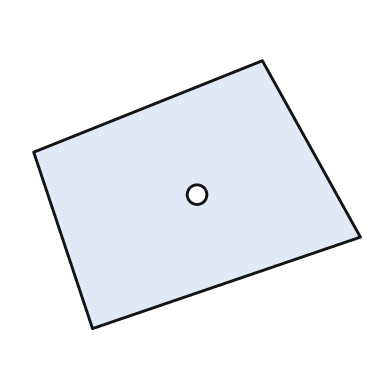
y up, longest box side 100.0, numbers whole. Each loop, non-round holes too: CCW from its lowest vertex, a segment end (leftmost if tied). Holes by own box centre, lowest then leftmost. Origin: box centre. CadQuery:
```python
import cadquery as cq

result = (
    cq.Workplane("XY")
    .moveTo(-32.0, -41.0)
    .lineTo(50.0, -13.0)
    .lineTo(20.0, 41.0)
    .lineTo(-50.0, 13.0)
    .close()
    .moveTo(0.0, 0.0)
    .circle(3.0)
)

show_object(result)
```